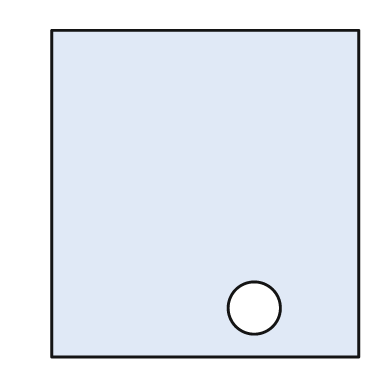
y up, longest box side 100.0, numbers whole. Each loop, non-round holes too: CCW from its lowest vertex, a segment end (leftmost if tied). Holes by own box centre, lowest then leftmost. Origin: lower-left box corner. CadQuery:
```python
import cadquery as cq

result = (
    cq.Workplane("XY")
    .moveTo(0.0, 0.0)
    .lineTo(94.0, 0.0)
    .lineTo(94.0, 100.0)
    .lineTo(0.0, 100.0)
    .close()
    .moveTo(62.0, 15.0)
    .circle(8.0)
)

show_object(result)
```